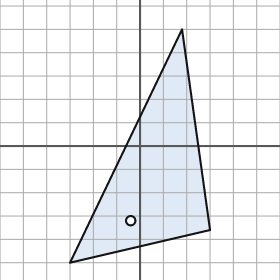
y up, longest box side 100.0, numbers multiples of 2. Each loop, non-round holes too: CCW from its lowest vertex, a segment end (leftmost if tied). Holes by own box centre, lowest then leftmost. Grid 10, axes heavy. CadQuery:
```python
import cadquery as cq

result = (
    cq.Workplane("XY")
    .moveTo(-30.0, -50.0)
    .lineTo(30.0, -36.0)
    .lineTo(18.0, 50.0)
    .close()
    .moveTo(-4.0, -32.0)
    .circle(2.0)
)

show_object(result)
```